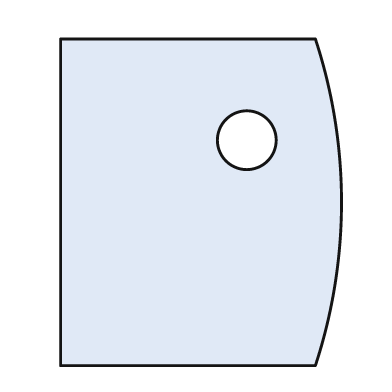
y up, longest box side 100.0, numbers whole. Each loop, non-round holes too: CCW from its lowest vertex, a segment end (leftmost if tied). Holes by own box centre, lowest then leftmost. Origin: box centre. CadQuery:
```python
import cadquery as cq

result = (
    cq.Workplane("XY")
    .moveTo(-43.0, -50.0)
    .lineTo(35.0, -50.0)
    .threePointArc((43.0, 0.0), (35.0, 50.0))
    .lineTo(-43.0, 50.0)
    .close()
    .moveTo(14.0, 19.0)
    .circle(9.0)
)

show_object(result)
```